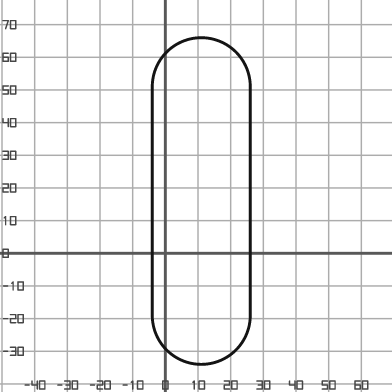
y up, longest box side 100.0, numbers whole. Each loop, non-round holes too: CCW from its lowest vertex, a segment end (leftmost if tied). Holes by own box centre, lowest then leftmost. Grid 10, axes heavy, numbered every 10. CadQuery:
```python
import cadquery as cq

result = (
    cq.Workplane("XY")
    .moveTo(-4.0, -19.0)
    .threePointArc((11.0, -34.0), (26.0, -19.0))
    .lineTo(26.0, 51.0)
    .threePointArc((11.0, 66.0), (-4.0, 51.0))
    .close()
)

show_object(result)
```